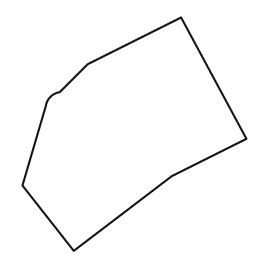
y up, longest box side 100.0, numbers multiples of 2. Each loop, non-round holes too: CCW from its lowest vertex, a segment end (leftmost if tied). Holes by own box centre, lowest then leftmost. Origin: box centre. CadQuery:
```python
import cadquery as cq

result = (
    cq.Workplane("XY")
    .moveTo(-26.0, -50.0)
    .lineTo(16.0, -18.0)
    .lineTo(48.0, -2.0)
    .lineTo(20.0, 50.0)
    .lineTo(-20.0, 30.0)
    .lineTo(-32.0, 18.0)
    .threePointArc((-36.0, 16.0), (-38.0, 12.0))
    .lineTo(-48.0, -22.0)
    .close()
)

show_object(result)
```